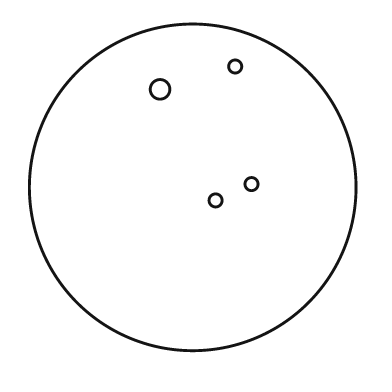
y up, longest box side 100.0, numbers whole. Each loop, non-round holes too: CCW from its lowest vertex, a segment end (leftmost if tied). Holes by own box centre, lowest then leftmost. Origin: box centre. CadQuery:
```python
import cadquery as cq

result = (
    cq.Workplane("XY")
    .moveTo(0.0, 0.0)
    .circle(50.0)
    .moveTo(7.0, -4.0)
    .circle(2.0)
    .moveTo(18.0, 1.0)
    .circle(2.0)
    .moveTo(-10.0, 30.0)
    .circle(3.0)
    .moveTo(13.0, 37.0)
    .circle(2.0)
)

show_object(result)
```